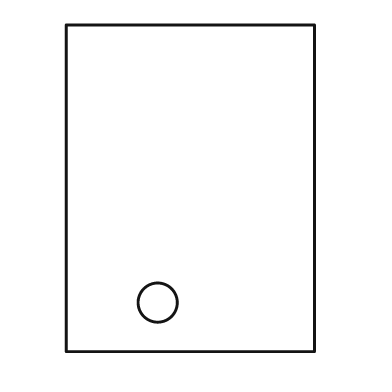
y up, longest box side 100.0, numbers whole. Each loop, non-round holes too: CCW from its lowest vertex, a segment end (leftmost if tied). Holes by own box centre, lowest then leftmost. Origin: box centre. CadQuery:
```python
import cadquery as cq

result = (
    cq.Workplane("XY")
    .moveTo(-38.0, -50.0)
    .lineTo(38.0, -50.0)
    .lineTo(38.0, 50.0)
    .lineTo(-38.0, 50.0)
    .close()
    .moveTo(-10.0, -35.0)
    .circle(6.0)
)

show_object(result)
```